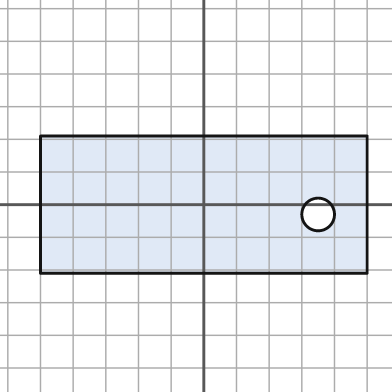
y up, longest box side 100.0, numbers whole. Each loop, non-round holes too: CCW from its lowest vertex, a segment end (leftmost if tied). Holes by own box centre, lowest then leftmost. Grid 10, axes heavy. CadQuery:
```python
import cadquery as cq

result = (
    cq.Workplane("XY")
    .moveTo(-50.0, -21.0)
    .lineTo(50.0, -21.0)
    .lineTo(50.0, 21.0)
    .lineTo(-50.0, 21.0)
    .close()
    .moveTo(35.0, -3.0)
    .circle(5.0)
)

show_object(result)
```